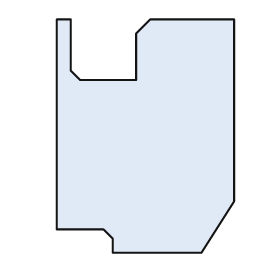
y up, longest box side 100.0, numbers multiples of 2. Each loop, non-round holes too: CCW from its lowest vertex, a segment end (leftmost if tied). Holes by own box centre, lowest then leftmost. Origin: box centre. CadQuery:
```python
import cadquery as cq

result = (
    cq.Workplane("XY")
    .moveTo(-14.0, -50.0)
    .lineTo(24.0, -50.0)
    .lineTo(38.0, -28.0)
    .lineTo(38.0, 50.0)
    .lineTo(2.0, 50.0)
    .lineTo(-4.0, 44.0)
    .lineTo(-4.0, 24.0)
    .lineTo(-28.0, 24.0)
    .lineTo(-32.0, 28.0)
    .lineTo(-32.0, 50.0)
    .lineTo(-38.0, 50.0)
    .lineTo(-38.0, -40.0)
    .lineTo(-18.0, -40.0)
    .lineTo(-14.0, -44.0)
    .close()
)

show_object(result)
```